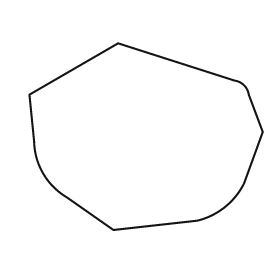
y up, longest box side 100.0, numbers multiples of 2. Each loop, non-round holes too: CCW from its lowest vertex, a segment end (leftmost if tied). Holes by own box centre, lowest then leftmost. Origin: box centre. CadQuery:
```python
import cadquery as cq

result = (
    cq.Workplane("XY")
    .moveTo(-14.0, -40.0)
    .lineTo(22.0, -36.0)
    .threePointArc((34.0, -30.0), (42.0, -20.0))
    .lineTo(50.0, 2.0)
    .lineTo(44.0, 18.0)
    .threePointArc((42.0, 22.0), (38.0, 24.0))
    .lineTo(-12.0, 40.0)
    .lineTo(-50.0, 18.0)
    .lineTo(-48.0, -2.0)
    .threePointArc((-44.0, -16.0), (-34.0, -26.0))
    .close()
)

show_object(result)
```